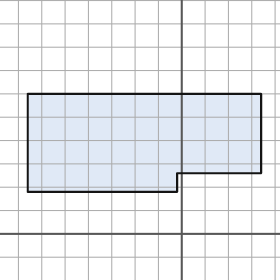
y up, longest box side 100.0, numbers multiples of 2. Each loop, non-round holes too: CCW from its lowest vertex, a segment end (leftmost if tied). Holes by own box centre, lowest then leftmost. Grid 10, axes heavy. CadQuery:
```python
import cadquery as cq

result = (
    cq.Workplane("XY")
    .moveTo(-66.0, 18.0)
    .lineTo(-2.0, 18.0)
    .lineTo(-2.0, 26.0)
    .lineTo(34.0, 26.0)
    .lineTo(34.0, 60.0)
    .lineTo(-66.0, 60.0)
    .close()
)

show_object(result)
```